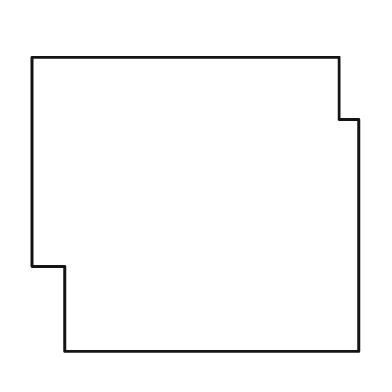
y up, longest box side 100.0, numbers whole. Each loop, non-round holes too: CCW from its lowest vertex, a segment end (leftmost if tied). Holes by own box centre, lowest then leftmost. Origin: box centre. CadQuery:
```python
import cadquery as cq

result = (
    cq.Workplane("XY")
    .moveTo(-40.0, -45.0)
    .lineTo(50.0, -45.0)
    .lineTo(50.0, 26.0)
    .lineTo(44.0, 26.0)
    .lineTo(44.0, 45.0)
    .lineTo(-50.0, 45.0)
    .lineTo(-50.0, -19.0)
    .lineTo(-40.0, -19.0)
    .close()
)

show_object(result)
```